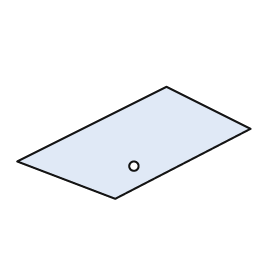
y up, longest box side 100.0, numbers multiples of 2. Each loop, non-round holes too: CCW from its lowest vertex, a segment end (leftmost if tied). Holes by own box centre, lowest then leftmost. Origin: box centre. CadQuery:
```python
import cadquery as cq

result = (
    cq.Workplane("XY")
    .moveTo(-8.0, -24.0)
    .lineTo(50.0, 6.0)
    .lineTo(14.0, 24.0)
    .lineTo(-50.0, -8.0)
    .close()
    .moveTo(0.0, -10.0)
    .circle(2.0)
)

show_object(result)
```